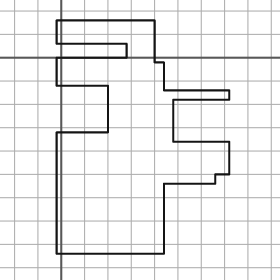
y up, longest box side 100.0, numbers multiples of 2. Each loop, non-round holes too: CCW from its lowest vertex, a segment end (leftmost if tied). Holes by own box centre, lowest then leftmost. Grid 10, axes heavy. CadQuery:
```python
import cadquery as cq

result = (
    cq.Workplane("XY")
    .moveTo(-2.0, -84.0)
    .lineTo(44.0, -84.0)
    .lineTo(44.0, -54.0)
    .lineTo(66.0, -54.0)
    .lineTo(66.0, -50.0)
    .lineTo(72.0, -50.0)
    .lineTo(72.0, -36.0)
    .lineTo(48.0, -36.0)
    .lineTo(48.0, -18.0)
    .lineTo(72.0, -18.0)
    .lineTo(72.0, -14.0)
    .lineTo(44.0, -14.0)
    .lineTo(44.0, -2.0)
    .lineTo(40.0, -2.0)
    .lineTo(40.0, 16.0)
    .lineTo(-2.0, 16.0)
    .lineTo(-2.0, 6.0)
    .lineTo(28.0, 6.0)
    .lineTo(28.0, 0.0)
    .lineTo(-2.0, 0.0)
    .lineTo(-2.0, -12.0)
    .lineTo(20.0, -12.0)
    .lineTo(20.0, -32.0)
    .lineTo(-2.0, -32.0)
    .close()
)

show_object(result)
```